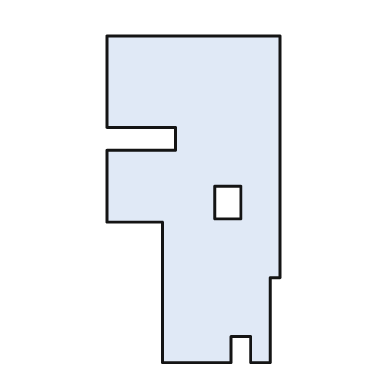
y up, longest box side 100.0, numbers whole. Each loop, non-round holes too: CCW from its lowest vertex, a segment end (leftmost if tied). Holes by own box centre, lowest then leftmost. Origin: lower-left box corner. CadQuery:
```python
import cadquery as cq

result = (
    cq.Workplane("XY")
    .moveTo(17.0, 0.0)
    .lineTo(38.0, 0.0)
    .lineTo(38.0, 8.0)
    .lineTo(44.0, 8.0)
    .lineTo(44.0, 0.0)
    .lineTo(50.0, 0.0)
    .lineTo(50.0, 26.0)
    .lineTo(53.0, 26.0)
    .lineTo(53.0, 100.0)
    .lineTo(0.0, 100.0)
    .lineTo(0.0, 72.0)
    .lineTo(21.0, 72.0)
    .lineTo(21.0, 65.0)
    .lineTo(0.0, 65.0)
    .lineTo(0.0, 43.0)
    .lineTo(17.0, 43.0)
    .close()
    .moveTo(33.0, 44.0)
    .lineTo(41.0, 44.0)
    .lineTo(41.0, 54.0)
    .lineTo(33.0, 54.0)
    .close()
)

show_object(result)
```